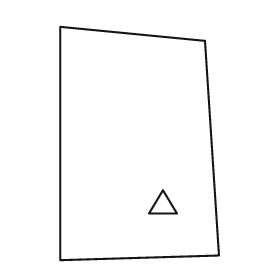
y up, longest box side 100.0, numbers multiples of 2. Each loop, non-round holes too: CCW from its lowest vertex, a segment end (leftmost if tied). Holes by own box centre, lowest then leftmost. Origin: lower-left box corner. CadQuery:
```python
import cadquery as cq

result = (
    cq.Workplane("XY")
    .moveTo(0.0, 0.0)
    .lineTo(68.0, 2.0)
    .lineTo(62.0, 94.0)
    .lineTo(0.0, 100.0)
    .close()
    .moveTo(38.0, 20.0)
    .lineTo(50.0, 20.0)
    .lineTo(44.0, 30.0)
    .close()
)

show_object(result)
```